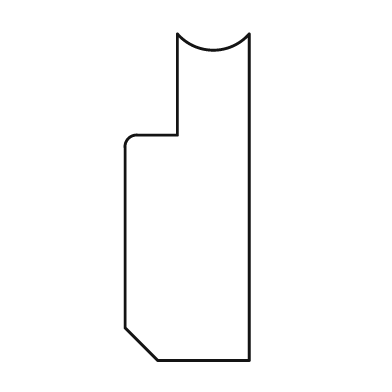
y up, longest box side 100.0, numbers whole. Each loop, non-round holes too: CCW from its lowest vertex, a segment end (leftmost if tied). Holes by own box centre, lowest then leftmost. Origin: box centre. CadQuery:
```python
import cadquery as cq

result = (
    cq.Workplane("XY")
    .moveTo(-9.0, -50.0)
    .lineTo(19.0, -50.0)
    .lineTo(19.0, 50.0)
    .threePointArc((8.0, 45.0), (-3.0, 50.0))
    .lineTo(-3.0, 19.0)
    .lineTo(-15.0, 19.0)
    .threePointArc((-18.0, 18.0), (-19.0, 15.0))
    .lineTo(-19.0, -40.0)
    .close()
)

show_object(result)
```